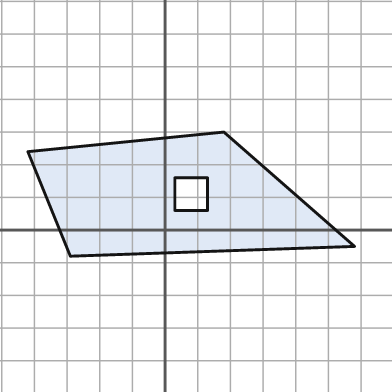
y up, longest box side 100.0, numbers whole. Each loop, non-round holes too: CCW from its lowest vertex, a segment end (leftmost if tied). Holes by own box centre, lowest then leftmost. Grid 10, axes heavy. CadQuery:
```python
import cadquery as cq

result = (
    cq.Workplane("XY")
    .moveTo(-29.0, -8.0)
    .lineTo(58.0, -5.0)
    .lineTo(18.0, 30.0)
    .lineTo(-42.0, 24.0)
    .close()
    .moveTo(3.0, 6.0)
    .lineTo(13.0, 6.0)
    .lineTo(13.0, 16.0)
    .lineTo(3.0, 16.0)
    .close()
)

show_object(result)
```